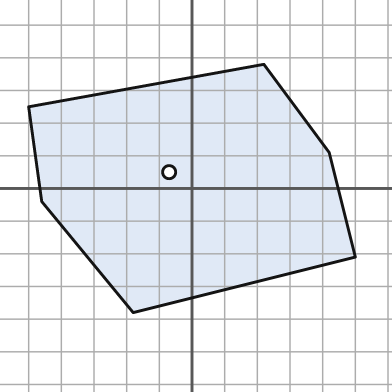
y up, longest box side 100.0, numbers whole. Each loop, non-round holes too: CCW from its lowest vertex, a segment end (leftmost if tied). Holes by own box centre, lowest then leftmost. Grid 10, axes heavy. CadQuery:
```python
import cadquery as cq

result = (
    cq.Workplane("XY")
    .moveTo(-18.0, -38.0)
    .lineTo(50.0, -21.0)
    .lineTo(42.0, 11.0)
    .lineTo(22.0, 38.0)
    .lineTo(-50.0, 25.0)
    .lineTo(-46.0, -4.0)
    .close()
    .moveTo(-7.0, 5.0)
    .circle(2.0)
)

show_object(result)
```